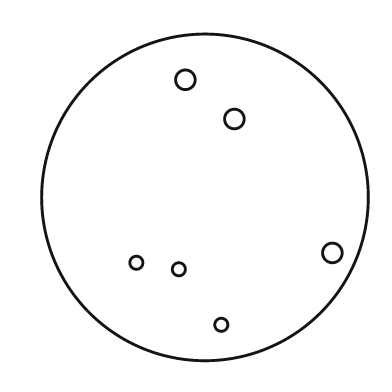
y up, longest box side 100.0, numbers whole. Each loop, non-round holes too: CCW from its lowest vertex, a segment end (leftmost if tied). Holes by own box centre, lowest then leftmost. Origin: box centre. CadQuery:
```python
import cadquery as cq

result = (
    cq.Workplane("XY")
    .moveTo(0.0, 0.0)
    .circle(50.0)
    .moveTo(5.0, -39.0)
    .circle(2.0)
    .moveTo(-8.0, -22.0)
    .circle(2.0)
    .moveTo(-21.0, -20.0)
    .circle(2.0)
    .moveTo(39.0, -17.0)
    .circle(3.0)
    .moveTo(9.0, 24.0)
    .circle(3.0)
    .moveTo(-6.0, 36.0)
    .circle(3.0)
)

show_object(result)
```